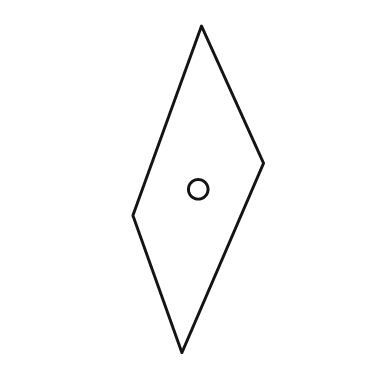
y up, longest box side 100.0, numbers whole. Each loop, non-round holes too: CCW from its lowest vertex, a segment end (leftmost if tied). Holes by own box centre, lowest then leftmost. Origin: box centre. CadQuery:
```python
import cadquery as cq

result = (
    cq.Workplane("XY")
    .moveTo(-5.0, -50.0)
    .lineTo(20.0, 8.0)
    .lineTo(1.0, 50.0)
    .lineTo(-20.0, -8.0)
    .close()
    .moveTo(0.0, 0.0)
    .circle(3.0)
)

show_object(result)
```